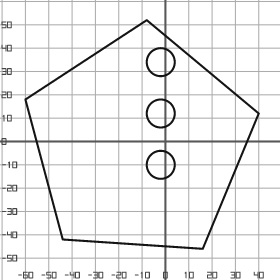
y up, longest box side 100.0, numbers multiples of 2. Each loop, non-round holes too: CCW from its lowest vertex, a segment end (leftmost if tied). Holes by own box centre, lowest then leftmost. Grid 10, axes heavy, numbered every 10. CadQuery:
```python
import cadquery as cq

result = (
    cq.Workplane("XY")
    .moveTo(16.0, -46.0)
    .lineTo(40.0, 12.0)
    .lineTo(-8.0, 52.0)
    .lineTo(-60.0, 18.0)
    .lineTo(-44.0, -42.0)
    .close()
    .moveTo(-2.0, -10.0)
    .circle(6.0)
    .moveTo(-2.0, 12.0)
    .circle(6.0)
    .moveTo(-2.0, 34.0)
    .circle(6.0)
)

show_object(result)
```